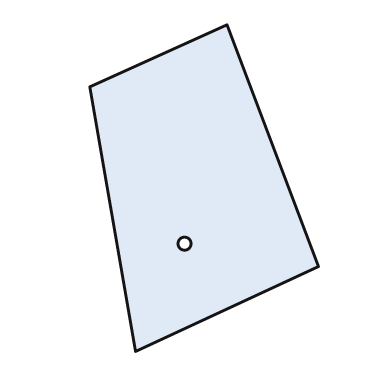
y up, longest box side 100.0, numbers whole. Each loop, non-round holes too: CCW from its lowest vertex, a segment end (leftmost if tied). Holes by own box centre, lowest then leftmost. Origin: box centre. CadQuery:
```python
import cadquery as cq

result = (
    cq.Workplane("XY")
    .moveTo(-21.0, -50.0)
    .lineTo(35.0, -24.0)
    .lineTo(7.0, 50.0)
    .lineTo(-35.0, 31.0)
    .close()
    .moveTo(-6.0, -17.0)
    .circle(2.0)
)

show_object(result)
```